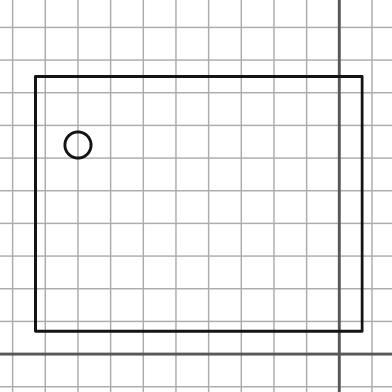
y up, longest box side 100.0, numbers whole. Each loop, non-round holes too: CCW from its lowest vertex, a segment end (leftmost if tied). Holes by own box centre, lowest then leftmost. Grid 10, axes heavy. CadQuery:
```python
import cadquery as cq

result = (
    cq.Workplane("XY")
    .moveTo(-93.0, 7.0)
    .lineTo(7.0, 7.0)
    .lineTo(7.0, 85.0)
    .lineTo(-93.0, 85.0)
    .close()
    .moveTo(-80.0, 64.0)
    .circle(4.0)
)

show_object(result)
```